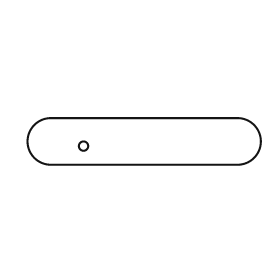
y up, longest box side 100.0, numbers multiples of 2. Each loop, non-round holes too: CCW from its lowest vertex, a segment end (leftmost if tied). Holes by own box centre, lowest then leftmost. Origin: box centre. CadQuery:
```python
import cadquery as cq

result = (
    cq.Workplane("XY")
    .moveTo(-40.0, -10.0)
    .lineTo(40.0, -10.0)
    .threePointArc((50.0, 0.0), (40.0, 10.0))
    .lineTo(-40.0, 10.0)
    .threePointArc((-50.0, 0.0), (-40.0, -10.0))
    .close()
    .moveTo(-26.0, -2.0)
    .circle(2.0)
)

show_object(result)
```